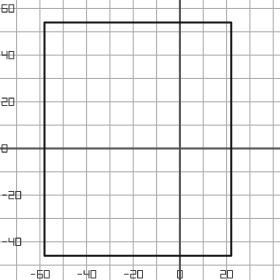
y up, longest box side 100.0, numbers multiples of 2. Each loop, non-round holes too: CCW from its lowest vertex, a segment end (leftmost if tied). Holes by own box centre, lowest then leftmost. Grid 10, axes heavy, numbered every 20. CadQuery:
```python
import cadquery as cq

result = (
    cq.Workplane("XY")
    .moveTo(-58.0, -46.0)
    .lineTo(22.0, -46.0)
    .lineTo(22.0, 54.0)
    .lineTo(-58.0, 54.0)
    .close()
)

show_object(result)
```